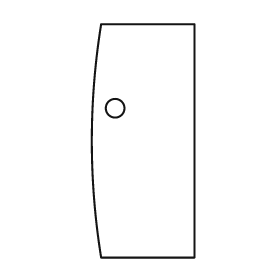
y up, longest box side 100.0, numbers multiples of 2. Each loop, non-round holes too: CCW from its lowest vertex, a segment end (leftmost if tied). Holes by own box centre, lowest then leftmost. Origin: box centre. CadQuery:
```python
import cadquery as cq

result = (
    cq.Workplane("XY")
    .moveTo(-18.0, -50.0)
    .lineTo(22.0, -50.0)
    .lineTo(22.0, 50.0)
    .lineTo(-18.0, 50.0)
    .threePointArc((-22.0, 0.0), (-18.0, -50.0))
    .close()
    .moveTo(-12.0, 14.0)
    .circle(4.0)
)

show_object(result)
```